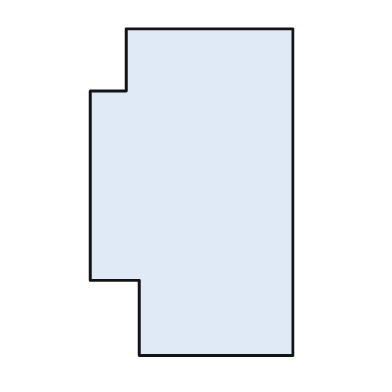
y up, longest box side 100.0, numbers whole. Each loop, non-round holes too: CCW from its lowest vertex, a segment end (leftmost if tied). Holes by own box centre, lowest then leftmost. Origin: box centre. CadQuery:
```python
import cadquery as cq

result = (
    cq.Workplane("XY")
    .moveTo(-16.0, -50.0)
    .lineTo(31.0, -50.0)
    .lineTo(31.0, 50.0)
    .lineTo(-20.0, 50.0)
    .lineTo(-20.0, 31.0)
    .lineTo(-31.0, 31.0)
    .lineTo(-31.0, -27.0)
    .lineTo(-16.0, -27.0)
    .close()
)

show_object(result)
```